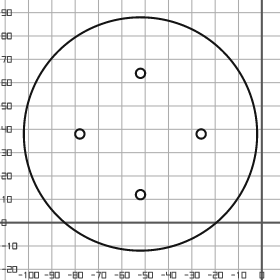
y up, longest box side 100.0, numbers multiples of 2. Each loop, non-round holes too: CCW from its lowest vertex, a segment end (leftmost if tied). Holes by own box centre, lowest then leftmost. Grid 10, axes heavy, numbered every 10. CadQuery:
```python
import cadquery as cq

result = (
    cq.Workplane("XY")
    .moveTo(-52.0, 38.0)
    .circle(50.0)
    .moveTo(-52.0, 12.0)
    .circle(2.0)
    .moveTo(-78.0, 38.0)
    .circle(2.0)
    .moveTo(-26.0, 38.0)
    .circle(2.0)
    .moveTo(-52.0, 64.0)
    .circle(2.0)
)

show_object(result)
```